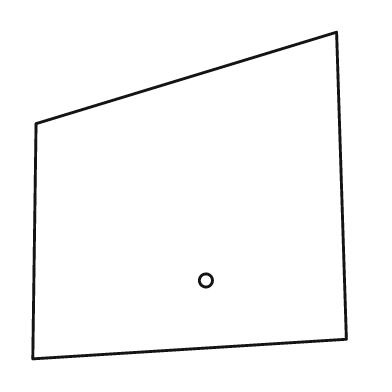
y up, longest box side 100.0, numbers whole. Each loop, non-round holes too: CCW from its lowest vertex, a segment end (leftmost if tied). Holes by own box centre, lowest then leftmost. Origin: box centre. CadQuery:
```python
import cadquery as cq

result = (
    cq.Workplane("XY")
    .moveTo(-48.0, -50.0)
    .lineTo(48.0, -44.0)
    .lineTo(45.0, 50.0)
    .lineTo(-47.0, 22.0)
    .close()
    .moveTo(5.0, -26.0)
    .circle(2.0)
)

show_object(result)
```